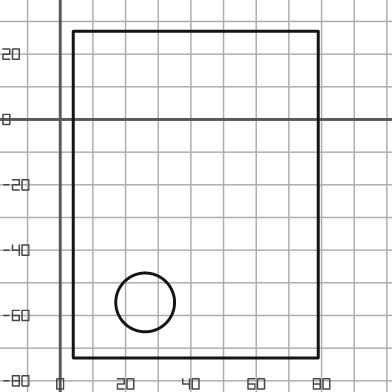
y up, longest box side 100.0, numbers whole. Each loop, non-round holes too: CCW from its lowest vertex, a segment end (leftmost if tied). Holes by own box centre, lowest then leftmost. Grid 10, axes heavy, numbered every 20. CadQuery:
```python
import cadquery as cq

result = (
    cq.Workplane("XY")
    .moveTo(4.0, -73.0)
    .lineTo(79.0, -73.0)
    .lineTo(79.0, 27.0)
    .lineTo(4.0, 27.0)
    .close()
    .moveTo(26.0, -56.0)
    .circle(9.0)
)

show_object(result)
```